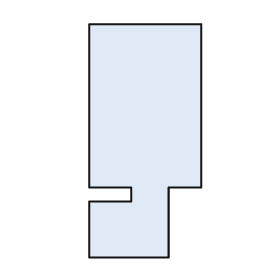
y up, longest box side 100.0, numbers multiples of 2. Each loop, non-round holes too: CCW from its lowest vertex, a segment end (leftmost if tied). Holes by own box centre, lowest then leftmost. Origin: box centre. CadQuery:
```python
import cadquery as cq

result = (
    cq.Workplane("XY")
    .moveTo(-24.0, -50.0)
    .lineTo(10.0, -50.0)
    .lineTo(10.0, -20.0)
    .lineTo(24.0, -20.0)
    .lineTo(24.0, 50.0)
    .lineTo(-24.0, 50.0)
    .lineTo(-24.0, -20.0)
    .lineTo(-6.0, -20.0)
    .lineTo(-6.0, -26.0)
    .lineTo(-24.0, -26.0)
    .close()
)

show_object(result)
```